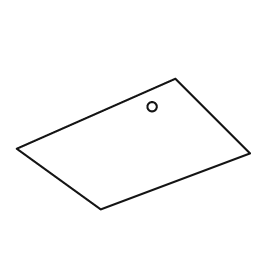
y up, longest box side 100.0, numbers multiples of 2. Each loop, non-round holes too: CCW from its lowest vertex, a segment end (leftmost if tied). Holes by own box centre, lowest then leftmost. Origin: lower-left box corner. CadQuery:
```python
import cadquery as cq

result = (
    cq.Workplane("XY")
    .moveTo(36.0, 0.0)
    .lineTo(100.0, 24.0)
    .lineTo(68.0, 56.0)
    .lineTo(0.0, 26.0)
    .close()
    .moveTo(58.0, 44.0)
    .circle(2.0)
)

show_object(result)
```